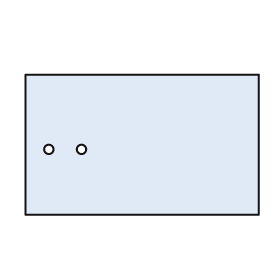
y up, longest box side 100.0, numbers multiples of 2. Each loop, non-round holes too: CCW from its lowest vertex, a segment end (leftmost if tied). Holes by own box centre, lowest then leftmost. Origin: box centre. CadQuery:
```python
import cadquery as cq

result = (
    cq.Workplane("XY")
    .moveTo(-50.0, -30.0)
    .lineTo(50.0, -30.0)
    .lineTo(50.0, 30.0)
    .lineTo(-50.0, 30.0)
    .close()
    .moveTo(-40.0, -2.0)
    .circle(2.0)
    .moveTo(-26.0, -2.0)
    .circle(2.0)
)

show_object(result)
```